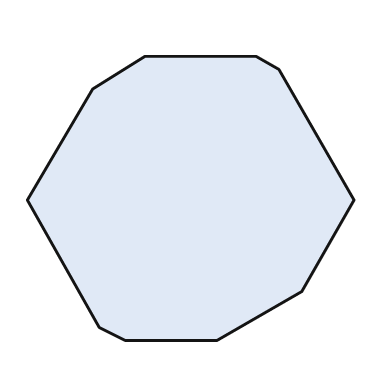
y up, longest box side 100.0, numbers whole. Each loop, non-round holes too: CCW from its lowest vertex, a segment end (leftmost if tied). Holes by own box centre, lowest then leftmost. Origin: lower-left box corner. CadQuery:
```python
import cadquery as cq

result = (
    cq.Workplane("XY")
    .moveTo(30.0, 0.0)
    .lineTo(58.0, 0.0)
    .lineTo(84.0, 15.0)
    .lineTo(100.0, 43.0)
    .lineTo(77.0, 83.0)
    .lineTo(70.0, 87.0)
    .lineTo(36.0, 87.0)
    .lineTo(20.0, 77.0)
    .lineTo(0.0, 43.0)
    .lineTo(22.0, 4.0)
    .close()
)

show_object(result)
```